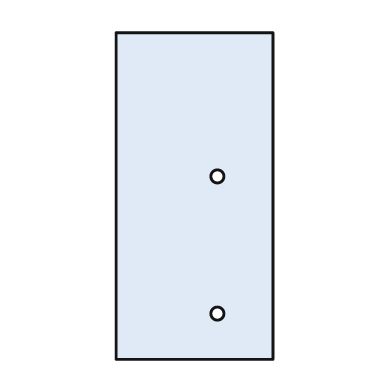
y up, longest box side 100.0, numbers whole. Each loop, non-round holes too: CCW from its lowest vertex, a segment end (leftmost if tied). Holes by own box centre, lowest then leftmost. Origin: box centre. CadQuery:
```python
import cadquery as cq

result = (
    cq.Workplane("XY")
    .moveTo(-24.0, -50.0)
    .lineTo(24.0, -50.0)
    .lineTo(24.0, 50.0)
    .lineTo(-24.0, 50.0)
    .close()
    .moveTo(7.0, -36.0)
    .circle(2.0)
    .moveTo(7.0, 6.0)
    .circle(2.0)
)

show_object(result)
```